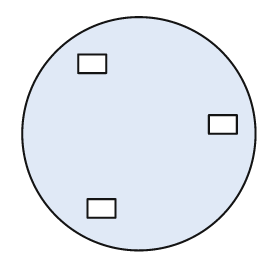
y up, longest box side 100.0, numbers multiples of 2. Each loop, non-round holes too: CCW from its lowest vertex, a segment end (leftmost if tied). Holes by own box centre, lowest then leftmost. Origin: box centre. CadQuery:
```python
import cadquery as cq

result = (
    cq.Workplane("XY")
    .moveTo(0.0, 0.0)
    .circle(50.0)
    .moveTo(-22.0, -36.0)
    .lineTo(-10.0, -36.0)
    .lineTo(-10.0, -28.0)
    .lineTo(-22.0, -28.0)
    .close()
    .moveTo(30.0, 0.0)
    .lineTo(42.0, 0.0)
    .lineTo(42.0, 8.0)
    .lineTo(30.0, 8.0)
    .close()
    .moveTo(-26.0, 26.0)
    .lineTo(-14.0, 26.0)
    .lineTo(-14.0, 34.0)
    .lineTo(-26.0, 34.0)
    .close()
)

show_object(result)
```